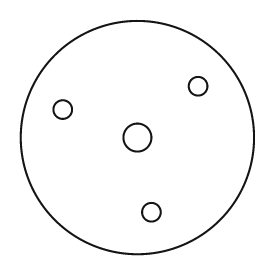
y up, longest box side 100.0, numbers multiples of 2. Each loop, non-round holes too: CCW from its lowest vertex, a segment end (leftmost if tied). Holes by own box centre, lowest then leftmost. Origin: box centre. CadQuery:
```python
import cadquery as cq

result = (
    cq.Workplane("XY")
    .moveTo(0.0, 0.0)
    .circle(50.0)
    .moveTo(6.0, -32.0)
    .circle(4.0)
    .moveTo(0.0, 0.0)
    .circle(6.0)
    .moveTo(-32.0, 12.0)
    .circle(4.0)
    .moveTo(26.0, 22.0)
    .circle(4.0)
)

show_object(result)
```